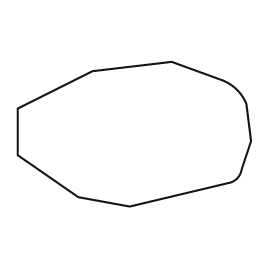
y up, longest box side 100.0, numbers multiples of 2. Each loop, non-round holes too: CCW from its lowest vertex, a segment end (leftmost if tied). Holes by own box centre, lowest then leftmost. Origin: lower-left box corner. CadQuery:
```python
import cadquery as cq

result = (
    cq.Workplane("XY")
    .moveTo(48.0, 0.0)
    .lineTo(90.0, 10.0)
    .threePointArc((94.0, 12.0), (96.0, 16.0))
    .lineTo(100.0, 28.0)
    .lineTo(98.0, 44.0)
    .threePointArc((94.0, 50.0), (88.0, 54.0))
    .lineTo(66.0, 62.0)
    .lineTo(32.0, 58.0)
    .lineTo(0.0, 42.0)
    .lineTo(0.0, 22.0)
    .lineTo(26.0, 4.0)
    .close()
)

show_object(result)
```